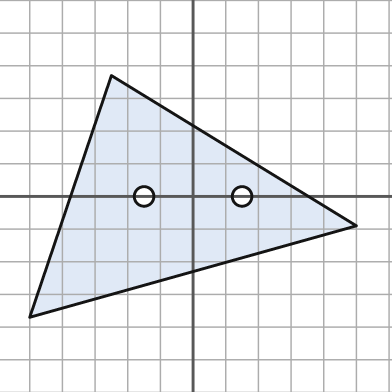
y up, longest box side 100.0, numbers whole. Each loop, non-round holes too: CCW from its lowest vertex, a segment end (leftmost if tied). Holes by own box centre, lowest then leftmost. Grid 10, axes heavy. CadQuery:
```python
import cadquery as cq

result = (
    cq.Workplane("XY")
    .moveTo(-50.0, -37.0)
    .lineTo(50.0, -9.0)
    .lineTo(-25.0, 37.0)
    .close()
    .moveTo(-15.0, 0.0)
    .circle(3.0)
    .moveTo(15.0, 0.0)
    .circle(3.0)
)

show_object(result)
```